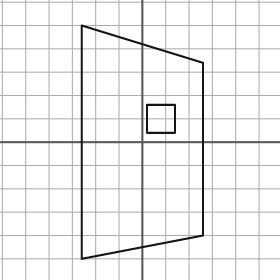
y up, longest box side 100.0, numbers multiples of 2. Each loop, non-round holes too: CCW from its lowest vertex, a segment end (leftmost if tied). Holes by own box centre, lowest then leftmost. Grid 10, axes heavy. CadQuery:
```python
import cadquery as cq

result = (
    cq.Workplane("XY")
    .moveTo(-26.0, -50.0)
    .lineTo(26.0, -40.0)
    .lineTo(26.0, 34.0)
    .lineTo(-26.0, 50.0)
    .close()
    .moveTo(2.0, 4.0)
    .lineTo(14.0, 4.0)
    .lineTo(14.0, 16.0)
    .lineTo(2.0, 16.0)
    .close()
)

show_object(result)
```